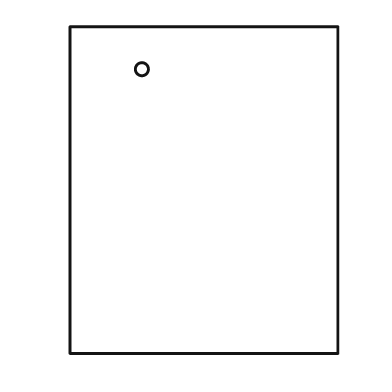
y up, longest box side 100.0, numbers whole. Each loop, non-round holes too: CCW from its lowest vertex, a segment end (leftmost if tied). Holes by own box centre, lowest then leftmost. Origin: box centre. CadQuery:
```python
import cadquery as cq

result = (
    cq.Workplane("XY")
    .moveTo(-41.0, -50.0)
    .lineTo(41.0, -50.0)
    .lineTo(41.0, 50.0)
    .lineTo(-41.0, 50.0)
    .close()
    .moveTo(-19.0, 37.0)
    .circle(2.0)
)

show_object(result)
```